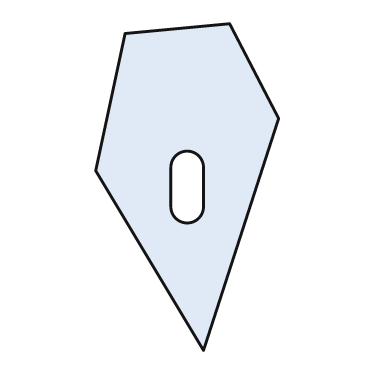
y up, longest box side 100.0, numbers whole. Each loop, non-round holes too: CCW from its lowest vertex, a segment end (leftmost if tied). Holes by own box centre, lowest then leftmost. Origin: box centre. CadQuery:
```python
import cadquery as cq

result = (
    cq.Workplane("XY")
    .moveTo(5.0, -50.0)
    .lineTo(28.0, 21.0)
    .lineTo(13.0, 50.0)
    .lineTo(-19.0, 47.0)
    .lineTo(-28.0, 5.0)
    .close()
    .moveTo(-5.0, -6.0)
    .threePointArc((0.0, -11.0), (5.0, -6.0))
    .lineTo(5.0, 6.0)
    .threePointArc((0.0, 11.0), (-5.0, 6.0))
    .close()
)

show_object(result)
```